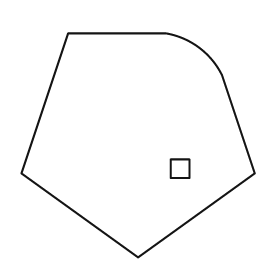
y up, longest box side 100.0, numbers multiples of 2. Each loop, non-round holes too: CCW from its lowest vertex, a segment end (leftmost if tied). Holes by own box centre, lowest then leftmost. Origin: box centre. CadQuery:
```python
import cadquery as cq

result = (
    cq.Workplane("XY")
    .moveTo(0.0, -48.0)
    .lineTo(50.0, -12.0)
    .lineTo(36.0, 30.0)
    .threePointArc((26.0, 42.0), (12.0, 48.0))
    .lineTo(-30.0, 48.0)
    .lineTo(-50.0, -12.0)
    .close()
    .moveTo(14.0, -14.0)
    .lineTo(22.0, -14.0)
    .lineTo(22.0, -6.0)
    .lineTo(14.0, -6.0)
    .close()
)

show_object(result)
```